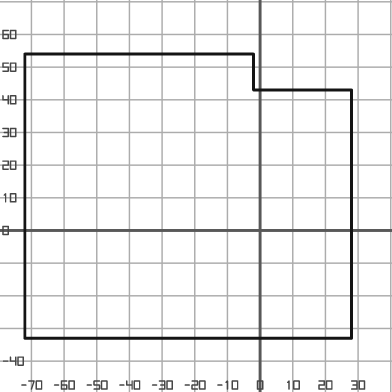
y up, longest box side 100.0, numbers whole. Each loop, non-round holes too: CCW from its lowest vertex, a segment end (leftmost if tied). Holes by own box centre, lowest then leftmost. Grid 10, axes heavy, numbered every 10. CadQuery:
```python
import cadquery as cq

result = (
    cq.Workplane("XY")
    .moveTo(-72.0, -33.0)
    .lineTo(28.0, -33.0)
    .lineTo(28.0, 43.0)
    .lineTo(-2.0, 43.0)
    .lineTo(-2.0, 54.0)
    .lineTo(-72.0, 54.0)
    .close()
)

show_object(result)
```